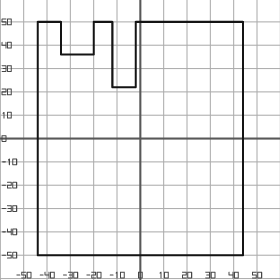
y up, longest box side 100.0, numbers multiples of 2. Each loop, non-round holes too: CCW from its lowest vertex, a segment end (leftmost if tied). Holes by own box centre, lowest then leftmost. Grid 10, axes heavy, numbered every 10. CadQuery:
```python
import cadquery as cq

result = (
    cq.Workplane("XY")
    .moveTo(-44.0, -50.0)
    .lineTo(44.0, -50.0)
    .lineTo(44.0, 50.0)
    .lineTo(-2.0, 50.0)
    .lineTo(-2.0, 22.0)
    .lineTo(-12.0, 22.0)
    .lineTo(-12.0, 50.0)
    .lineTo(-20.0, 50.0)
    .lineTo(-20.0, 36.0)
    .lineTo(-34.0, 36.0)
    .lineTo(-34.0, 50.0)
    .lineTo(-44.0, 50.0)
    .close()
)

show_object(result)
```